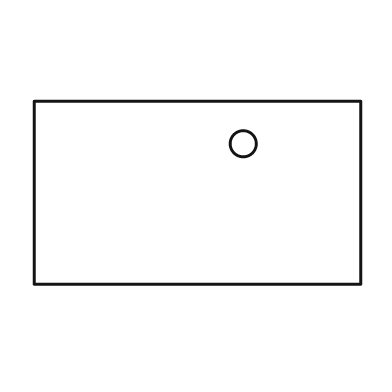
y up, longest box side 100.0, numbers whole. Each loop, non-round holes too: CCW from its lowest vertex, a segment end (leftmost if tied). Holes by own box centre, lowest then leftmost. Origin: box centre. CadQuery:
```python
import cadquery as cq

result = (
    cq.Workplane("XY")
    .moveTo(-50.0, -28.0)
    .lineTo(50.0, -28.0)
    .lineTo(50.0, 28.0)
    .lineTo(-50.0, 28.0)
    .close()
    .moveTo(14.0, 15.0)
    .circle(4.0)
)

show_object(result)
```